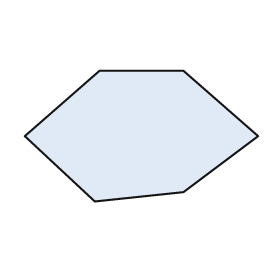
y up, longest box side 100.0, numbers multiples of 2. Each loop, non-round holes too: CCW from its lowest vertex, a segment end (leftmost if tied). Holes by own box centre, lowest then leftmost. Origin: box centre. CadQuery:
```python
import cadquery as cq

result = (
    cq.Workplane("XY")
    .moveTo(-20.0, -28.0)
    .lineTo(18.0, -24.0)
    .lineTo(50.0, 0.0)
    .lineTo(18.0, 28.0)
    .lineTo(-18.0, 28.0)
    .lineTo(-50.0, 0.0)
    .close()
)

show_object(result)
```